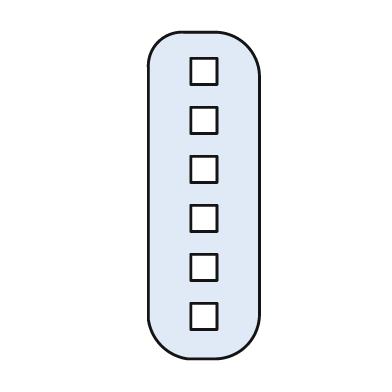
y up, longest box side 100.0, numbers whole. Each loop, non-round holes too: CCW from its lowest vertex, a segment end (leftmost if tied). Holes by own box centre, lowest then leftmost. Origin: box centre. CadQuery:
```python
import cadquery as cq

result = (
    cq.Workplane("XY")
    .moveTo(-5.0, -50.0)
    .lineTo(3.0, -50.0)
    .threePointArc((13.0, -46.0), (17.0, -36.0))
    .lineTo(17.0, 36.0)
    .threePointArc((13.0, 46.0), (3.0, 50.0))
    .lineTo(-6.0, 50.0)
    .threePointArc((-14.0, 47.0), (-17.0, 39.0))
    .lineTo(-17.0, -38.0)
    .threePointArc((-13.0, -46.0), (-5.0, -50.0))
    .close()
    .moveTo(-4.0, -41.0)
    .lineTo(4.0, -41.0)
    .lineTo(4.0, -33.0)
    .lineTo(-4.0, -33.0)
    .close()
    .moveTo(-4.0, -26.0)
    .lineTo(4.0, -26.0)
    .lineTo(4.0, -18.0)
    .lineTo(-4.0, -18.0)
    .close()
    .moveTo(-4.0, -11.0)
    .lineTo(4.0, -11.0)
    .lineTo(4.0, -3.0)
    .lineTo(-4.0, -3.0)
    .close()
    .moveTo(-4.0, 4.0)
    .lineTo(4.0, 4.0)
    .lineTo(4.0, 12.0)
    .lineTo(-4.0, 12.0)
    .close()
    .moveTo(-4.0, 19.0)
    .lineTo(4.0, 19.0)
    .lineTo(4.0, 27.0)
    .lineTo(-4.0, 27.0)
    .close()
    .moveTo(-4.0, 34.0)
    .lineTo(4.0, 34.0)
    .lineTo(4.0, 42.0)
    .lineTo(-4.0, 42.0)
    .close()
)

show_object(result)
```